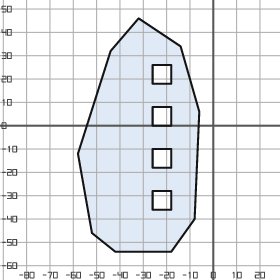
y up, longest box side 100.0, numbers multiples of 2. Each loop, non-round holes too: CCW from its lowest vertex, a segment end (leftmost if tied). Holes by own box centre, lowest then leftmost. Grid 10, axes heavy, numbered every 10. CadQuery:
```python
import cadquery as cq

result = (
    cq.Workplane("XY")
    .moveTo(-42.0, -54.0)
    .lineTo(-18.0, -54.0)
    .lineTo(-8.0, -40.0)
    .lineTo(-6.0, 6.0)
    .lineTo(-14.0, 34.0)
    .lineTo(-32.0, 46.0)
    .lineTo(-44.0, 32.0)
    .lineTo(-58.0, -12.0)
    .lineTo(-52.0, -46.0)
    .close()
    .moveTo(-26.0, -36.0)
    .lineTo(-18.0, -36.0)
    .lineTo(-18.0, -28.0)
    .lineTo(-26.0, -28.0)
    .close()
    .moveTo(-26.0, -18.0)
    .lineTo(-18.0, -18.0)
    .lineTo(-18.0, -10.0)
    .lineTo(-26.0, -10.0)
    .close()
    .moveTo(-26.0, 0.0)
    .lineTo(-18.0, 0.0)
    .lineTo(-18.0, 8.0)
    .lineTo(-26.0, 8.0)
    .close()
    .moveTo(-26.0, 18.0)
    .lineTo(-18.0, 18.0)
    .lineTo(-18.0, 26.0)
    .lineTo(-26.0, 26.0)
    .close()
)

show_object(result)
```